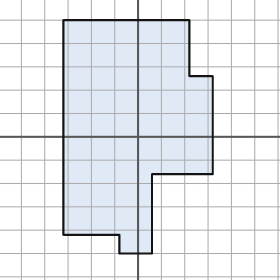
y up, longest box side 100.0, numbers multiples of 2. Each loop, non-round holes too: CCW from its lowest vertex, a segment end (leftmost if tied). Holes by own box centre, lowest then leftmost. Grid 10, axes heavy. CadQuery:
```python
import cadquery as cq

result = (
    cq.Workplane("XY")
    .moveTo(-8.0, -50.0)
    .lineTo(6.0, -50.0)
    .lineTo(6.0, -16.0)
    .lineTo(32.0, -16.0)
    .lineTo(32.0, 26.0)
    .lineTo(22.0, 26.0)
    .lineTo(22.0, 50.0)
    .lineTo(-32.0, 50.0)
    .lineTo(-32.0, -42.0)
    .lineTo(-8.0, -42.0)
    .close()
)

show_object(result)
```